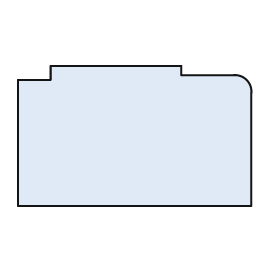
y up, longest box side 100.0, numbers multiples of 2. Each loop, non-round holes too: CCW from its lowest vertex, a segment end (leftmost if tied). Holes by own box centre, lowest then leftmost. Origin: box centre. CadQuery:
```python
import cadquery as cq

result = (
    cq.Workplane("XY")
    .moveTo(-50.0, -30.0)
    .lineTo(50.0, -30.0)
    .lineTo(50.0, 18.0)
    .threePointArc((48.0, 24.0), (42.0, 26.0))
    .lineTo(20.0, 26.0)
    .lineTo(20.0, 30.0)
    .lineTo(-36.0, 30.0)
    .lineTo(-36.0, 24.0)
    .lineTo(-50.0, 24.0)
    .close()
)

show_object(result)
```